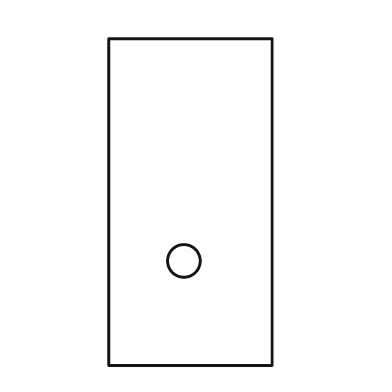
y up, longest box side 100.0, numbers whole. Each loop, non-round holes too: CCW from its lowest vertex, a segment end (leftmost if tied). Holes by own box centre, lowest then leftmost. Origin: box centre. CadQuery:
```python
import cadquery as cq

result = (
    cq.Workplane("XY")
    .moveTo(-25.0, -50.0)
    .lineTo(25.0, -50.0)
    .lineTo(25.0, 50.0)
    .lineTo(-25.0, 50.0)
    .close()
    .moveTo(-2.0, -18.0)
    .circle(5.0)
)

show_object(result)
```